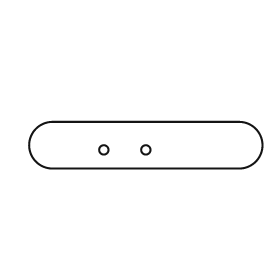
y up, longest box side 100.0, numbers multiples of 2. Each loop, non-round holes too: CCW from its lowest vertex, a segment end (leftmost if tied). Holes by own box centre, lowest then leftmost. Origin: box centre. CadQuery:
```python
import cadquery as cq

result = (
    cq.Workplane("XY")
    .moveTo(-40.0, -10.0)
    .lineTo(40.0, -10.0)
    .threePointArc((50.0, 0.0), (40.0, 10.0))
    .lineTo(-40.0, 10.0)
    .threePointArc((-50.0, 0.0), (-40.0, -10.0))
    .close()
    .moveTo(-18.0, -2.0)
    .circle(2.0)
    .moveTo(0.0, -2.0)
    .circle(2.0)
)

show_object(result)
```